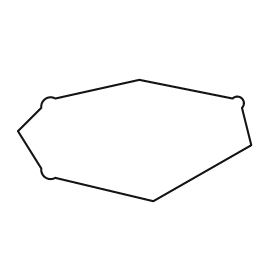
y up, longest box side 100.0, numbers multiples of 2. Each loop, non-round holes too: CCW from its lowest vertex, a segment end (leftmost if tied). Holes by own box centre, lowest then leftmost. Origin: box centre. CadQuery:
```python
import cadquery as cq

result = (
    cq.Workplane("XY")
    .moveTo(8.0, -26.0)
    .lineTo(50.0, -2.0)
    .lineTo(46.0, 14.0)
    .threePointArc((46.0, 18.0), (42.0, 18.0))
    .lineTo(2.0, 26.0)
    .lineTo(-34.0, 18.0)
    .threePointArc((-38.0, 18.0), (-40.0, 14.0))
    .lineTo(-50.0, 4.0)
    .lineTo(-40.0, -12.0)
    .threePointArc((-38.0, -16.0), (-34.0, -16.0))
    .close()
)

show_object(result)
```